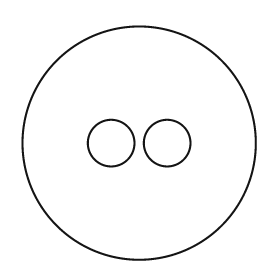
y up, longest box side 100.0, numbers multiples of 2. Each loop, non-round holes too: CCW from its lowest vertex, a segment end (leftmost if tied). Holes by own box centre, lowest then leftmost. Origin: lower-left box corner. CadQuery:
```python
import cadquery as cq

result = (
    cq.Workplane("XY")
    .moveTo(50.0, 50.0)
    .circle(50.0)
    .moveTo(38.0, 50.0)
    .circle(10.0)
    .moveTo(62.0, 50.0)
    .circle(10.0)
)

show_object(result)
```